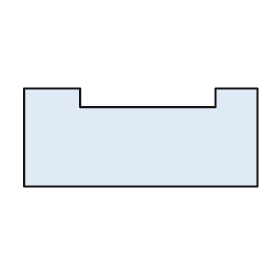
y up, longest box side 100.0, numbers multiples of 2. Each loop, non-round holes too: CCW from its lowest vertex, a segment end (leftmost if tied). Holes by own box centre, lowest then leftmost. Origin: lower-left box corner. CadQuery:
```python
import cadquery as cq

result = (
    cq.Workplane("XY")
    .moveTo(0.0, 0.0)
    .lineTo(100.0, 0.0)
    .lineTo(100.0, 42.0)
    .lineTo(82.0, 42.0)
    .lineTo(82.0, 34.0)
    .lineTo(24.0, 34.0)
    .lineTo(24.0, 42.0)
    .lineTo(0.0, 42.0)
    .close()
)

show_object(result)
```